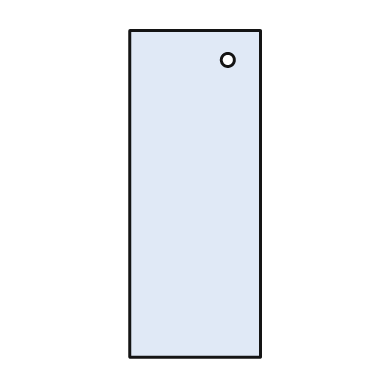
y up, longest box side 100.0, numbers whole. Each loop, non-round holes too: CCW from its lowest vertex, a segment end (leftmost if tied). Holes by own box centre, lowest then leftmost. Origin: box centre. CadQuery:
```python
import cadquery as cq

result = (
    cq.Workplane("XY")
    .moveTo(-20.0, -50.0)
    .lineTo(20.0, -50.0)
    .lineTo(20.0, 50.0)
    .lineTo(-20.0, 50.0)
    .close()
    .moveTo(10.0, 41.0)
    .circle(2.0)
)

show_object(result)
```